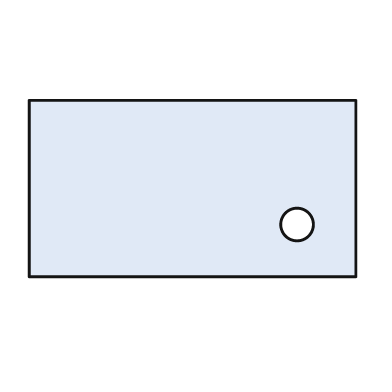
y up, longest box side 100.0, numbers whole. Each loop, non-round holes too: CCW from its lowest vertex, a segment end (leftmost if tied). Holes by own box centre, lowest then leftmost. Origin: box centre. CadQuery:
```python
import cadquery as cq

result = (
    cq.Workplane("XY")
    .moveTo(-50.0, -27.0)
    .lineTo(50.0, -27.0)
    .lineTo(50.0, 27.0)
    .lineTo(-50.0, 27.0)
    .close()
    .moveTo(32.0, -11.0)
    .circle(5.0)
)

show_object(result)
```